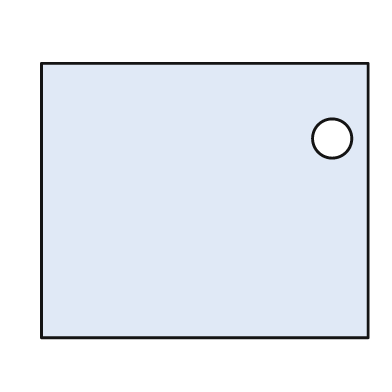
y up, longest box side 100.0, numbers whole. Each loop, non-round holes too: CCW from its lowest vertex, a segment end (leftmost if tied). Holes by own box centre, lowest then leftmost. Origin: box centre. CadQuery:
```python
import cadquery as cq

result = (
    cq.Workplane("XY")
    .moveTo(-50.0, -42.0)
    .lineTo(50.0, -42.0)
    .lineTo(50.0, 42.0)
    .lineTo(-50.0, 42.0)
    .close()
    .moveTo(39.0, 19.0)
    .circle(6.0)
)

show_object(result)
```